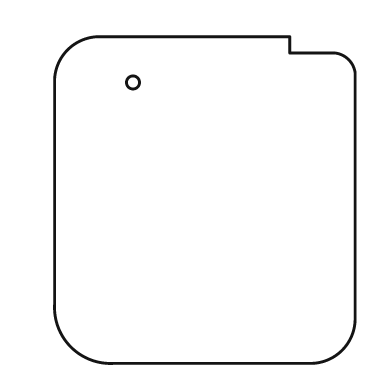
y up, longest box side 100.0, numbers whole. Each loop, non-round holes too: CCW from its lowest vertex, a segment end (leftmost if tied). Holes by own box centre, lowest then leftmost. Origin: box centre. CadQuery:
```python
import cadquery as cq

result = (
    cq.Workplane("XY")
    .moveTo(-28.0, -50.0)
    .lineTo(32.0, -50.0)
    .threePointArc((42.0, -46.0), (46.0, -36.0))
    .lineTo(46.0, 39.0)
    .threePointArc((44.0, 43.0), (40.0, 45.0))
    .lineTo(26.0, 45.0)
    .lineTo(26.0, 50.0)
    .lineTo(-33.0, 50.0)
    .threePointArc((-42.0, 46.0), (-46.0, 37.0))
    .lineTo(-46.0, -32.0)
    .threePointArc((-41.0, -45.0), (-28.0, -50.0))
    .close()
    .moveTo(-22.0, 36.0)
    .circle(2.0)
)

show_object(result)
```